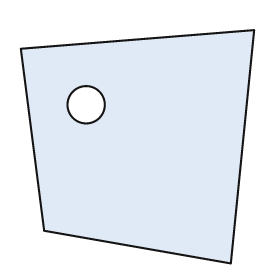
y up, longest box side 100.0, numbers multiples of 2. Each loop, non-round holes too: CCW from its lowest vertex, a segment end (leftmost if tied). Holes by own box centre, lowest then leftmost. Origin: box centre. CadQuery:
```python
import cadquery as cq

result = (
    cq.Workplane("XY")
    .moveTo(40.0, -50.0)
    .lineTo(50.0, 50.0)
    .lineTo(-50.0, 42.0)
    .lineTo(-40.0, -36.0)
    .close()
    .moveTo(-22.0, 18.0)
    .circle(8.0)
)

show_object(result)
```